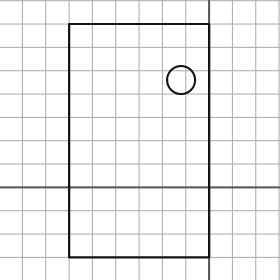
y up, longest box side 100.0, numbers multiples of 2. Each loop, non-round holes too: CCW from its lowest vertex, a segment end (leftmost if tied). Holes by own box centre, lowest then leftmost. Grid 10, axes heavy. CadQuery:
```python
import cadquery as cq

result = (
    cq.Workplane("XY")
    .moveTo(-60.0, -30.0)
    .lineTo(0.0, -30.0)
    .lineTo(0.0, 70.0)
    .lineTo(-60.0, 70.0)
    .close()
    .moveTo(-12.0, 46.0)
    .circle(6.0)
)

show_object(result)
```